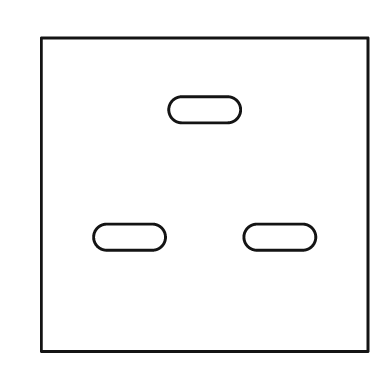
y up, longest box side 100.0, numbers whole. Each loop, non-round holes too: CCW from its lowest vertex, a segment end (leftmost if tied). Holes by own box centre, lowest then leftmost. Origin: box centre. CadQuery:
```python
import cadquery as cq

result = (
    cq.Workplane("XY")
    .moveTo(-50.0, -48.0)
    .lineTo(50.0, -48.0)
    .lineTo(50.0, 48.0)
    .lineTo(-50.0, 48.0)
    .close()
    .moveTo(-30.0, -17.0)
    .lineTo(-16.0, -17.0)
    .threePointArc((-12.0, -13.0), (-16.0, -9.0))
    .lineTo(-30.0, -9.0)
    .threePointArc((-34.0, -13.0), (-30.0, -17.0))
    .close()
    .moveTo(16.0, -17.0)
    .lineTo(30.0, -17.0)
    .threePointArc((34.0, -13.0), (30.0, -9.0))
    .lineTo(16.0, -9.0)
    .threePointArc((12.0, -13.0), (16.0, -17.0))
    .close()
    .moveTo(-7.0, 22.0)
    .lineTo(7.0, 22.0)
    .threePointArc((11.0, 26.0), (7.0, 30.0))
    .lineTo(-7.0, 30.0)
    .threePointArc((-11.0, 26.0), (-7.0, 22.0))
    .close()
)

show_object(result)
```